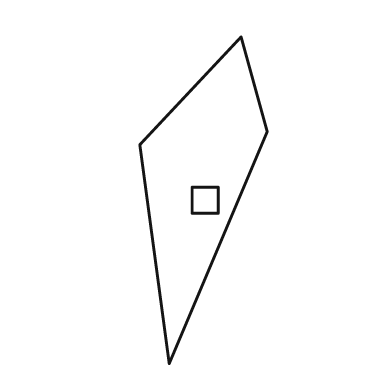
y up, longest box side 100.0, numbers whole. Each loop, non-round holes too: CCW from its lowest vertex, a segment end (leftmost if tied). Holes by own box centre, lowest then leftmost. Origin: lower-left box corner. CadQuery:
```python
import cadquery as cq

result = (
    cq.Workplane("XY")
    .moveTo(9.0, 0.0)
    .lineTo(39.0, 71.0)
    .lineTo(31.0, 100.0)
    .lineTo(0.0, 67.0)
    .close()
    .moveTo(16.0, 46.0)
    .lineTo(24.0, 46.0)
    .lineTo(24.0, 54.0)
    .lineTo(16.0, 54.0)
    .close()
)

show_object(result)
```